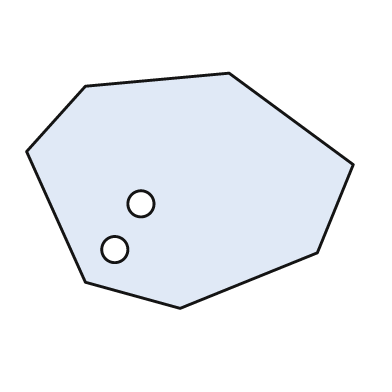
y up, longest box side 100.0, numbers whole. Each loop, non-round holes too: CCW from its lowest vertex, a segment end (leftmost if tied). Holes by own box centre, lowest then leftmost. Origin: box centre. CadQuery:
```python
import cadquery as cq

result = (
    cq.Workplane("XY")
    .moveTo(-3.0, -36.0)
    .lineTo(39.0, -19.0)
    .lineTo(50.0, 8.0)
    .lineTo(12.0, 36.0)
    .lineTo(-32.0, 32.0)
    .lineTo(-50.0, 12.0)
    .lineTo(-32.0, -28.0)
    .close()
    .moveTo(-23.0, -18.0)
    .circle(4.0)
    .moveTo(-15.0, -4.0)
    .circle(4.0)
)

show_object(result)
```